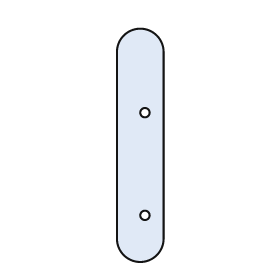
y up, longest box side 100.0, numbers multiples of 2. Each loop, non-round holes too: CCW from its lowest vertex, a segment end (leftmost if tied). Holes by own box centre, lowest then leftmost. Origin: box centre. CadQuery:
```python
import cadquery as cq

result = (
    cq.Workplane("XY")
    .moveTo(-10.0, -40.0)
    .threePointArc((0.0, -50.0), (10.0, -40.0))
    .lineTo(10.0, 40.0)
    .threePointArc((0.0, 50.0), (-10.0, 40.0))
    .close()
    .moveTo(2.0, -30.0)
    .circle(2.0)
    .moveTo(2.0, 14.0)
    .circle(2.0)
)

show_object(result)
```